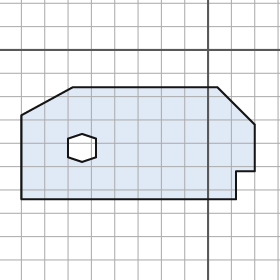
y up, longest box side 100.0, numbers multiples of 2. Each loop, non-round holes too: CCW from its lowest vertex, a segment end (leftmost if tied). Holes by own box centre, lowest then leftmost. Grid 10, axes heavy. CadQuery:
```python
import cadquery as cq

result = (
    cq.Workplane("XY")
    .moveTo(-80.0, -64.0)
    .lineTo(12.0, -64.0)
    .lineTo(12.0, -52.0)
    .lineTo(20.0, -52.0)
    .lineTo(20.0, -32.0)
    .lineTo(4.0, -16.0)
    .lineTo(-58.0, -16.0)
    .lineTo(-80.0, -28.0)
    .close()
    .moveTo(-54.0, -48.0)
    .lineTo(-48.0, -46.0)
    .lineTo(-48.0, -38.0)
    .lineTo(-54.0, -36.0)
    .lineTo(-60.0, -38.0)
    .lineTo(-60.0, -46.0)
    .close()
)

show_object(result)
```